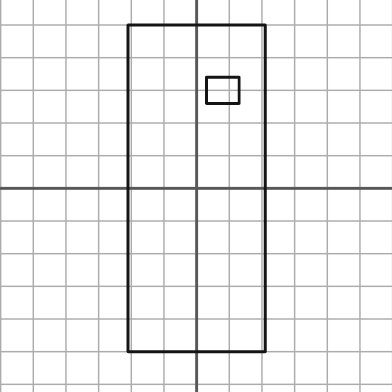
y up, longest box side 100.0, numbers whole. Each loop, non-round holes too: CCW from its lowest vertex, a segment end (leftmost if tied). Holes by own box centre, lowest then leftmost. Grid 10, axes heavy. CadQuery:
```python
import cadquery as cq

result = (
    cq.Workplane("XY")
    .moveTo(-21.0, -50.0)
    .lineTo(21.0, -50.0)
    .lineTo(21.0, 50.0)
    .lineTo(-21.0, 50.0)
    .close()
    .moveTo(3.0, 26.0)
    .lineTo(13.0, 26.0)
    .lineTo(13.0, 34.0)
    .lineTo(3.0, 34.0)
    .close()
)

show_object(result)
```